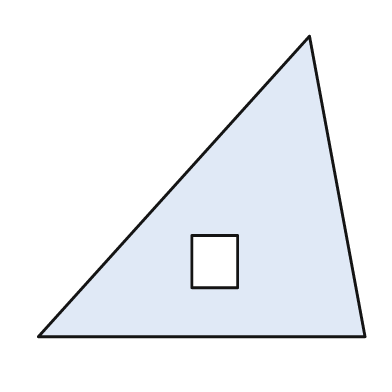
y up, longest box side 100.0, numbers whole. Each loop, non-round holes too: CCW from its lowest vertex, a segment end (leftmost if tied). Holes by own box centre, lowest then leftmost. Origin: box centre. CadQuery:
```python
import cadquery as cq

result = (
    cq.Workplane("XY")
    .moveTo(-50.0, -46.0)
    .lineTo(50.0, -46.0)
    .lineTo(33.0, 46.0)
    .close()
    .moveTo(-3.0, -31.0)
    .lineTo(11.0, -31.0)
    .lineTo(11.0, -15.0)
    .lineTo(-3.0, -15.0)
    .close()
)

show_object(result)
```